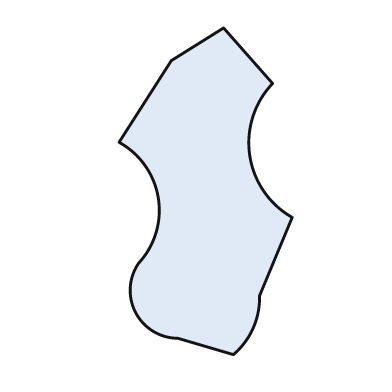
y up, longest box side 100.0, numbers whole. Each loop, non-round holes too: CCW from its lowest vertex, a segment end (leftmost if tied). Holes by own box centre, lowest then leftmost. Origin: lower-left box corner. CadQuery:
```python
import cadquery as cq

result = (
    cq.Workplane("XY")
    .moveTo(35.0, 0.0)
    .threePointArc((41.0, 8.0), (43.0, 18.0))
    .lineTo(53.0, 42.0)
    .threePointArc((40.0, 61.0), (47.0, 83.0))
    .lineTo(32.0, 100.0)
    .lineTo(16.0, 90.0)
    .lineTo(0.0, 65.0)
    .threePointArc((12.0, 48.0), (6.0, 28.0))
    .threePointArc((5.0, 13.0), (18.0, 5.0))
    .close()
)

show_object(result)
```